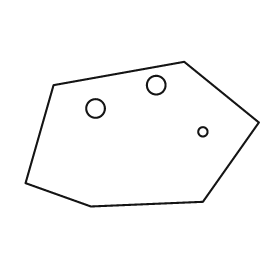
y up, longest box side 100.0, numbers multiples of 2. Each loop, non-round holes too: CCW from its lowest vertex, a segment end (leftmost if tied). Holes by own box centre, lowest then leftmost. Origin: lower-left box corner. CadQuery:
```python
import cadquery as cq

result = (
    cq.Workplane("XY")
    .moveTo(28.0, 0.0)
    .lineTo(76.0, 2.0)
    .lineTo(100.0, 36.0)
    .lineTo(68.0, 62.0)
    .lineTo(12.0, 52.0)
    .lineTo(0.0, 10.0)
    .close()
    .moveTo(76.0, 32.0)
    .circle(2.0)
    .moveTo(30.0, 42.0)
    .circle(4.0)
    .moveTo(56.0, 52.0)
    .circle(4.0)
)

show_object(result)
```